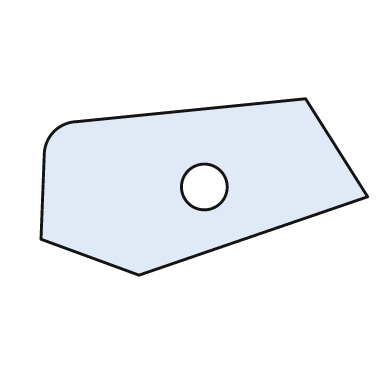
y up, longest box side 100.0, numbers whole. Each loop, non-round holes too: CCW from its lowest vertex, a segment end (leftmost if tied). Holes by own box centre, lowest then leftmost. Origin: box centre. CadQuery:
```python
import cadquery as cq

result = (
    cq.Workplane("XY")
    .moveTo(-20.0, -27.0)
    .lineTo(50.0, -3.0)
    .lineTo(31.0, 27.0)
    .lineTo(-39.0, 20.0)
    .threePointArc((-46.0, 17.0), (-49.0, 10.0))
    .lineTo(-50.0, -16.0)
    .close()
    .moveTo(0.0, 0.0)
    .circle(7.0)
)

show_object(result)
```